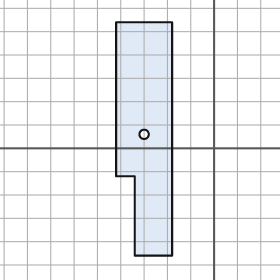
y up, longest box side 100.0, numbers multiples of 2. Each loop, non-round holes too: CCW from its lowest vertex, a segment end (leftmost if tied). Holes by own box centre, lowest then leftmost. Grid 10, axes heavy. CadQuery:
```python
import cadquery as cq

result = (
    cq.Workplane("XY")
    .moveTo(-34.0, -46.0)
    .lineTo(-18.0, -46.0)
    .lineTo(-18.0, 54.0)
    .lineTo(-42.0, 54.0)
    .lineTo(-42.0, -12.0)
    .lineTo(-34.0, -12.0)
    .close()
    .moveTo(-30.0, 6.0)
    .circle(2.0)
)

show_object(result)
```